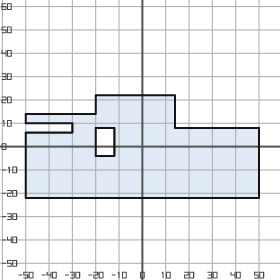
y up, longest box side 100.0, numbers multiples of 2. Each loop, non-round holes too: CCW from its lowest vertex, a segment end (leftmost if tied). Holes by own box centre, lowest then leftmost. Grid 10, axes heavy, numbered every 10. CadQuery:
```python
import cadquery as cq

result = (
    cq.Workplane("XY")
    .moveTo(-50.0, -22.0)
    .lineTo(50.0, -22.0)
    .lineTo(50.0, 8.0)
    .lineTo(14.0, 8.0)
    .lineTo(14.0, 22.0)
    .lineTo(-20.0, 22.0)
    .lineTo(-20.0, 14.0)
    .lineTo(-50.0, 14.0)
    .lineTo(-50.0, 10.0)
    .lineTo(-30.0, 10.0)
    .lineTo(-30.0, 6.0)
    .lineTo(-50.0, 6.0)
    .close()
    .moveTo(-20.0, -4.0)
    .lineTo(-12.0, -4.0)
    .lineTo(-12.0, 8.0)
    .lineTo(-20.0, 8.0)
    .close()
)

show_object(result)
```